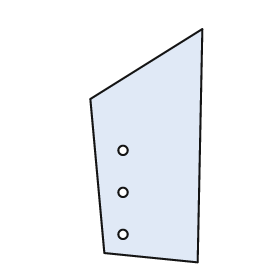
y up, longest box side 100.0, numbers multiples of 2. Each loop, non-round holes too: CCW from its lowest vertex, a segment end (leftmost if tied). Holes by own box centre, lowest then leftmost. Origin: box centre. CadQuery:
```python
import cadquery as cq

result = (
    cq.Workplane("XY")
    .moveTo(22.0, -50.0)
    .lineTo(24.0, 50.0)
    .lineTo(-24.0, 20.0)
    .lineTo(-18.0, -46.0)
    .close()
    .moveTo(-10.0, -38.0)
    .circle(2.0)
    .moveTo(-10.0, -20.0)
    .circle(2.0)
    .moveTo(-10.0, -2.0)
    .circle(2.0)
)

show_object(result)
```